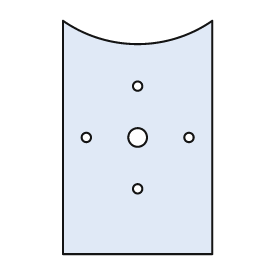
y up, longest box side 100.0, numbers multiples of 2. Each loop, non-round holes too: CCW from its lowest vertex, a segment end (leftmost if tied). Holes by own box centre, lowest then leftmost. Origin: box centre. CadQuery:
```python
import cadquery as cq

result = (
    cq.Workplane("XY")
    .moveTo(-32.0, -50.0)
    .lineTo(32.0, -50.0)
    .lineTo(32.0, 50.0)
    .threePointArc((0.0, 40.0), (-32.0, 50.0))
    .close()
    .moveTo(0.0, -22.0)
    .circle(2.0)
    .moveTo(-22.0, 0.0)
    .circle(2.0)
    .moveTo(0.0, 0.0)
    .circle(4.0)
    .moveTo(22.0, 0.0)
    .circle(2.0)
    .moveTo(0.0, 22.0)
    .circle(2.0)
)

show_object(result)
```